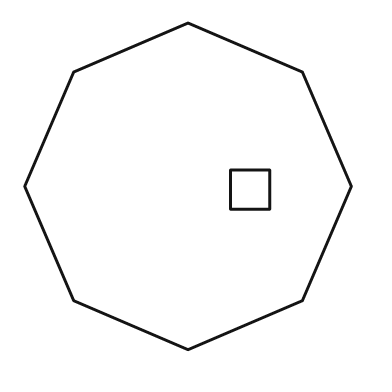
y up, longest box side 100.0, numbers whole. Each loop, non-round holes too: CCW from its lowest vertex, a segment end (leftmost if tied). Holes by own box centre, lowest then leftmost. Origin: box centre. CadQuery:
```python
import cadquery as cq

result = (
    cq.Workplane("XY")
    .moveTo(0.0, -50.0)
    .lineTo(35.0, -35.0)
    .lineTo(50.0, 0.0)
    .lineTo(35.0, 35.0)
    .lineTo(0.0, 50.0)
    .lineTo(-35.0, 35.0)
    .lineTo(-50.0, 0.0)
    .lineTo(-35.0, -35.0)
    .close()
    .moveTo(13.0, -7.0)
    .lineTo(25.0, -7.0)
    .lineTo(25.0, 5.0)
    .lineTo(13.0, 5.0)
    .close()
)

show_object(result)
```